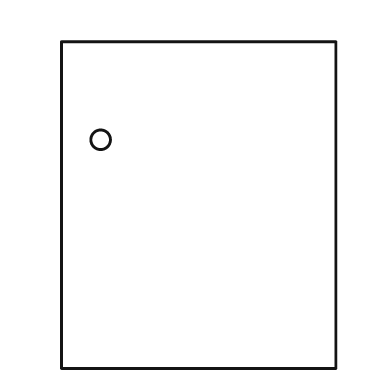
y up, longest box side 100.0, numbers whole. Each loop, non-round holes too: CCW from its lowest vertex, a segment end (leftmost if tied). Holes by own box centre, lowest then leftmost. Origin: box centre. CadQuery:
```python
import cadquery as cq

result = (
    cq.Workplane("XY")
    .moveTo(-42.0, -50.0)
    .lineTo(42.0, -50.0)
    .lineTo(42.0, 50.0)
    .lineTo(-42.0, 50.0)
    .close()
    .moveTo(-30.0, 20.0)
    .circle(3.0)
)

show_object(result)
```